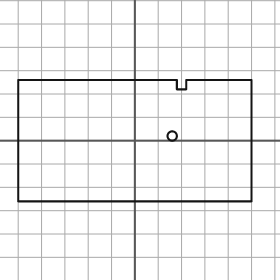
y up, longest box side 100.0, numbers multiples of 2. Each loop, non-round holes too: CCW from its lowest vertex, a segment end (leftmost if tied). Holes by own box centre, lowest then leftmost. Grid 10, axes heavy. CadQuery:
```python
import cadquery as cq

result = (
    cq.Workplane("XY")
    .moveTo(-50.0, -26.0)
    .lineTo(50.0, -26.0)
    .lineTo(50.0, 26.0)
    .lineTo(22.0, 26.0)
    .lineTo(22.0, 22.0)
    .lineTo(18.0, 22.0)
    .lineTo(18.0, 26.0)
    .lineTo(-50.0, 26.0)
    .close()
    .moveTo(16.0, 2.0)
    .circle(2.0)
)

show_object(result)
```